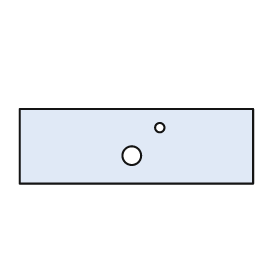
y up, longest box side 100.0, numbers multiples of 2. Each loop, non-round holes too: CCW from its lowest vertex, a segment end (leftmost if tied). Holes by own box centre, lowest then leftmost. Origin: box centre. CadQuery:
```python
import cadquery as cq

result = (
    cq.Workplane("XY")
    .moveTo(-50.0, -16.0)
    .lineTo(50.0, -16.0)
    .lineTo(50.0, 16.0)
    .lineTo(-50.0, 16.0)
    .close()
    .moveTo(-2.0, -4.0)
    .circle(4.0)
    .moveTo(10.0, 8.0)
    .circle(2.0)
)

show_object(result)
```